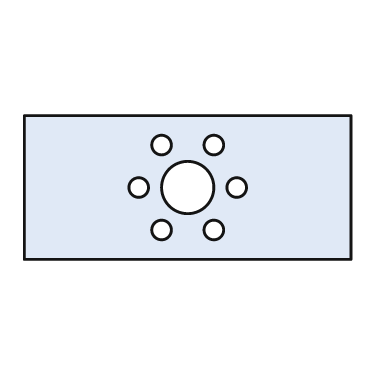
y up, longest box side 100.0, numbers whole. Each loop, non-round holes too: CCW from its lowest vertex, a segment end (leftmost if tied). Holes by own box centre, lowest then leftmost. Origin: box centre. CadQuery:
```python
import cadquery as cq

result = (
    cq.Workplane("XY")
    .moveTo(-50.0, -22.0)
    .lineTo(50.0, -22.0)
    .lineTo(50.0, 22.0)
    .lineTo(-50.0, 22.0)
    .close()
    .moveTo(-8.0, -13.0)
    .circle(3.0)
    .moveTo(8.0, -13.0)
    .circle(3.0)
    .moveTo(-15.0, 0.0)
    .circle(3.0)
    .moveTo(0.0, 0.0)
    .circle(8.0)
    .moveTo(15.0, 0.0)
    .circle(3.0)
    .moveTo(-8.0, 13.0)
    .circle(3.0)
    .moveTo(8.0, 13.0)
    .circle(3.0)
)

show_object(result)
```